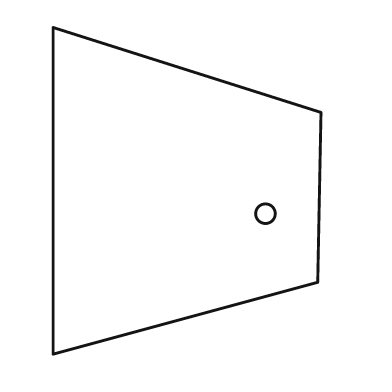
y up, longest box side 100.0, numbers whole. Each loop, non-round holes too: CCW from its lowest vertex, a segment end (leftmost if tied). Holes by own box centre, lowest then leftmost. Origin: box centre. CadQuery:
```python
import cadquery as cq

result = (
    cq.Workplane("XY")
    .moveTo(-41.0, -50.0)
    .lineTo(40.0, -28.0)
    .lineTo(41.0, 24.0)
    .lineTo(-41.0, 50.0)
    .close()
    .moveTo(24.0, -7.0)
    .circle(3.0)
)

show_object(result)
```